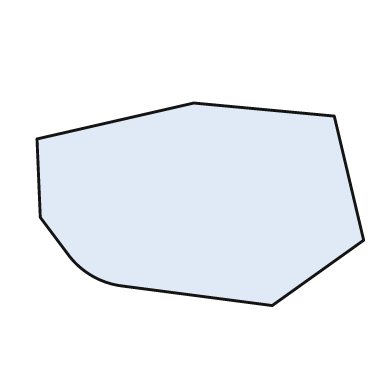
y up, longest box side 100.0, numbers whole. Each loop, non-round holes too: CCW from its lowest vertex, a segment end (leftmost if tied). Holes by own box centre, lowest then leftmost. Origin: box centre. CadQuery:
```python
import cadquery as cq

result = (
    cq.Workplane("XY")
    .moveTo(22.0, -31.0)
    .lineTo(50.0, -11.0)
    .lineTo(41.0, 27.0)
    .lineTo(-2.0, 31.0)
    .lineTo(-50.0, 20.0)
    .lineTo(-49.0, -4.0)
    .lineTo(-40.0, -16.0)
    .threePointArc((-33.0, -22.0), (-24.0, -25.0))
    .close()
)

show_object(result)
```